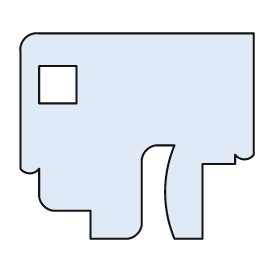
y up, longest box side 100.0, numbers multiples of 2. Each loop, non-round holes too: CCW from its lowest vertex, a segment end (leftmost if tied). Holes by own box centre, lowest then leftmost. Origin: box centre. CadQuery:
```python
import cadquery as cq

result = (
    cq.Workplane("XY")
    .moveTo(-20.0, -44.0)
    .lineTo(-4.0, -44.0)
    .threePointArc((0.0, -42.0), (2.0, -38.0))
    .lineTo(2.0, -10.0)
    .threePointArc((4.0, -6.0), (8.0, -4.0))
    .lineTo(16.0, -4.0)
    .threePointArc((12.0, -24.0), (16.0, -44.0))
    .lineTo(28.0, -44.0)
    .lineTo(28.0, -12.0)
    .lineTo(42.0, -12.0)
    .lineTo(42.0, -8.0)
    .threePointArc((46.0, -10.0), (50.0, -8.0))
    .lineTo(50.0, 44.0)
    .lineTo(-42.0, 44.0)
    .threePointArc((-48.0, 42.0), (-50.0, 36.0))
    .lineTo(-50.0, -14.0)
    .threePointArc((-46.0, -16.0), (-42.0, -14.0))
    .lineTo(-42.0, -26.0)
    .threePointArc((-40.0, -30.0), (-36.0, -32.0))
    .lineTo(-20.0, -32.0)
    .close()
    .moveTo(-42.0, 14.0)
    .lineTo(-26.0, 14.0)
    .lineTo(-26.0, 30.0)
    .lineTo(-42.0, 30.0)
    .close()
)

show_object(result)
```